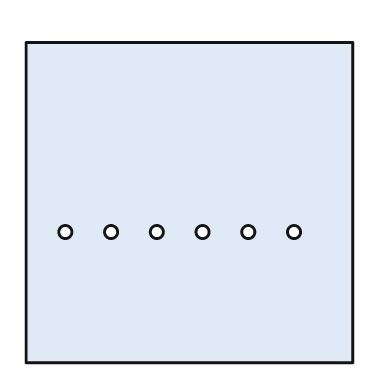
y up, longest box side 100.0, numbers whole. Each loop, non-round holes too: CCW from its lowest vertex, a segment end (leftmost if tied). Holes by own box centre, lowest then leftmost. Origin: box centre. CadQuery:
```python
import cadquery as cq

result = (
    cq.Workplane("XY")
    .moveTo(-50.0, -49.0)
    .lineTo(50.0, -49.0)
    .lineTo(50.0, 49.0)
    .lineTo(-50.0, 49.0)
    .close()
    .moveTo(-38.0, -9.0)
    .circle(2.0)
    .moveTo(-24.0, -9.0)
    .circle(2.0)
    .moveTo(-10.0, -9.0)
    .circle(2.0)
    .moveTo(4.0, -9.0)
    .circle(2.0)
    .moveTo(18.0, -9.0)
    .circle(2.0)
    .moveTo(32.0, -9.0)
    .circle(2.0)
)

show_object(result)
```